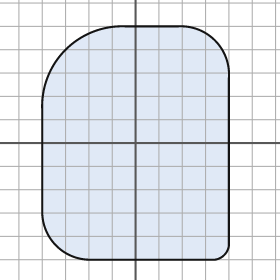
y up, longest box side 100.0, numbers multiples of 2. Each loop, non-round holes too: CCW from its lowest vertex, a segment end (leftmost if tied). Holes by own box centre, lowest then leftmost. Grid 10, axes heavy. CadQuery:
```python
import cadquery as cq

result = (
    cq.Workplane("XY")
    .moveTo(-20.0, -50.0)
    .lineTo(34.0, -50.0)
    .threePointArc((38.0, -48.0), (40.0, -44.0))
    .lineTo(40.0, 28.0)
    .threePointArc((34.0, 44.0), (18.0, 50.0))
    .lineTo(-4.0, 50.0)
    .threePointArc((-30.0, 40.0), (-40.0, 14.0))
    .lineTo(-40.0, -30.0)
    .threePointArc((-34.0, -44.0), (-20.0, -50.0))
    .close()
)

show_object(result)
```